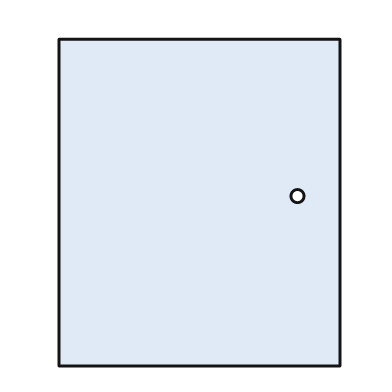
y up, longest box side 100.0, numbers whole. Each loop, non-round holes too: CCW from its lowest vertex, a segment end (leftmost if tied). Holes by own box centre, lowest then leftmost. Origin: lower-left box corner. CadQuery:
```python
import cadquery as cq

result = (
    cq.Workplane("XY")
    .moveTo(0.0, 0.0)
    .lineTo(86.0, 0.0)
    .lineTo(86.0, 100.0)
    .lineTo(0.0, 100.0)
    .close()
    .moveTo(73.0, 52.0)
    .circle(2.0)
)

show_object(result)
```